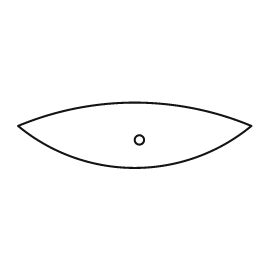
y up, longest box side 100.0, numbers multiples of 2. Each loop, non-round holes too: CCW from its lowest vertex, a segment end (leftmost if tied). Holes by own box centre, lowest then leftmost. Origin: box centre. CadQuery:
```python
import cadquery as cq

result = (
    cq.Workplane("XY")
    .moveTo(-50.0, 4.0)
    .threePointArc((0.0, -14.0), (50.0, 4.0))
    .threePointArc((0.0, 14.0), (-50.0, 4.0))
    .close()
    .moveTo(2.0, -2.0)
    .circle(2.0)
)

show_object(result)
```